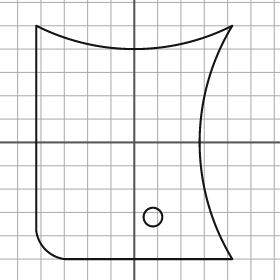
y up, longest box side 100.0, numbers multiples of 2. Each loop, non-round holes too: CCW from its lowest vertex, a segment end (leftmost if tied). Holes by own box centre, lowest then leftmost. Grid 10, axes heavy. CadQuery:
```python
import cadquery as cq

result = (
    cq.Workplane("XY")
    .moveTo(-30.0, -50.0)
    .lineTo(42.0, -50.0)
    .threePointArc((28.0, 0.0), (42.0, 50.0))
    .threePointArc((0.0, 40.0), (-42.0, 50.0))
    .lineTo(-42.0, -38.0)
    .threePointArc((-38.0, -46.0), (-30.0, -50.0))
    .close()
    .moveTo(8.0, -32.0)
    .circle(4.0)
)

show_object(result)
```